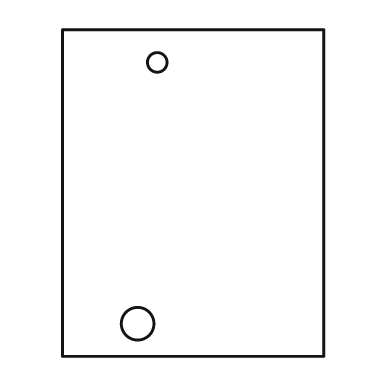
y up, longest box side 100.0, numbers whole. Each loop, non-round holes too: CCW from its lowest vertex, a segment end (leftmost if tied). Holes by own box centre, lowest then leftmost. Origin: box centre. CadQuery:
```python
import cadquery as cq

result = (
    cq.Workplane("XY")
    .moveTo(-40.0, -50.0)
    .lineTo(40.0, -50.0)
    .lineTo(40.0, 50.0)
    .lineTo(-40.0, 50.0)
    .close()
    .moveTo(-17.0, -40.0)
    .circle(5.0)
    .moveTo(-11.0, 40.0)
    .circle(3.0)
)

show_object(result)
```